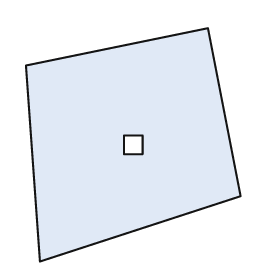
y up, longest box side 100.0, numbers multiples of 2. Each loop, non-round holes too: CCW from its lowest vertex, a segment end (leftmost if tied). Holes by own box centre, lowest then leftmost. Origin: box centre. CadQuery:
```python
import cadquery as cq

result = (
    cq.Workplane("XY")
    .moveTo(-40.0, -50.0)
    .lineTo(46.0, -22.0)
    .lineTo(32.0, 50.0)
    .lineTo(-46.0, 34.0)
    .close()
    .moveTo(-4.0, -4.0)
    .lineTo(4.0, -4.0)
    .lineTo(4.0, 4.0)
    .lineTo(-4.0, 4.0)
    .close()
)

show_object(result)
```